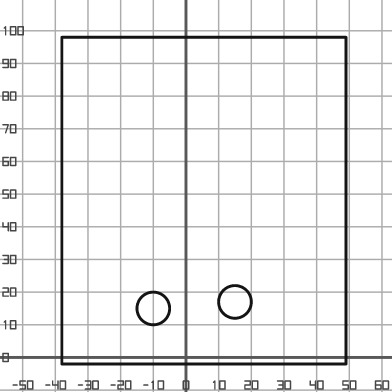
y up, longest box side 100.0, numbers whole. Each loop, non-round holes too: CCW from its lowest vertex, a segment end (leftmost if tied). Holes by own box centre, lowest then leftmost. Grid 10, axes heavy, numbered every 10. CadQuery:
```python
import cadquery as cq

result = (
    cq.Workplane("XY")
    .moveTo(-38.0, -2.0)
    .lineTo(49.0, -2.0)
    .lineTo(49.0, 98.0)
    .lineTo(-38.0, 98.0)
    .close()
    .moveTo(-10.0, 15.0)
    .circle(5.0)
    .moveTo(15.0, 17.0)
    .circle(5.0)
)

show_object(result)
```